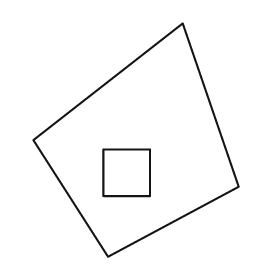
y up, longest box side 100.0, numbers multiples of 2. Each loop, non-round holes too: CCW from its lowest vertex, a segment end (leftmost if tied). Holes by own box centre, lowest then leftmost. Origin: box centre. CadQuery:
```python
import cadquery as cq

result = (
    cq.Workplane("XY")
    .moveTo(-12.0, -50.0)
    .lineTo(44.0, -20.0)
    .lineTo(20.0, 50.0)
    .lineTo(-44.0, 0.0)
    .close()
    .moveTo(-14.0, -24.0)
    .lineTo(6.0, -24.0)
    .lineTo(6.0, -4.0)
    .lineTo(-14.0, -4.0)
    .close()
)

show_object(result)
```